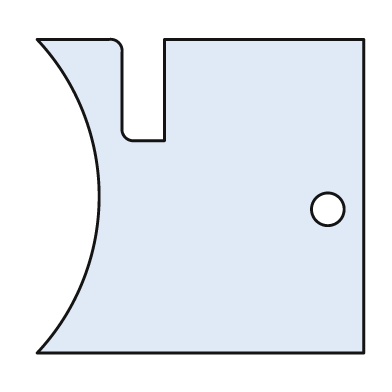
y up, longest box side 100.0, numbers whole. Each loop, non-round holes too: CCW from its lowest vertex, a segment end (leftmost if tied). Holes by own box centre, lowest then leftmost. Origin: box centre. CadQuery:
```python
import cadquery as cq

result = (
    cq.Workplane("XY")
    .moveTo(-50.0, -48.0)
    .lineTo(50.0, -48.0)
    .lineTo(50.0, 48.0)
    .lineTo(-11.0, 48.0)
    .lineTo(-11.0, 17.0)
    .lineTo(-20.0, 17.0)
    .threePointArc((-23.0, 18.0), (-24.0, 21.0))
    .lineTo(-24.0, 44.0)
    .threePointArc((-25.0, 47.0), (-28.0, 48.0))
    .lineTo(-50.0, 48.0)
    .threePointArc((-31.0, 0.0), (-50.0, -48.0))
    .close()
    .moveTo(39.0, -4.0)
    .circle(5.0)
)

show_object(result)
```